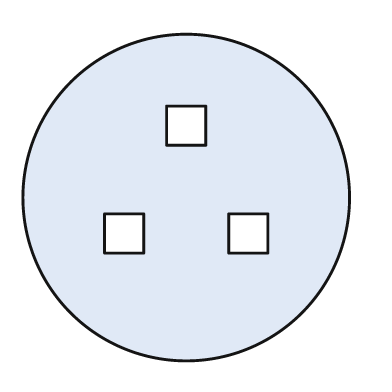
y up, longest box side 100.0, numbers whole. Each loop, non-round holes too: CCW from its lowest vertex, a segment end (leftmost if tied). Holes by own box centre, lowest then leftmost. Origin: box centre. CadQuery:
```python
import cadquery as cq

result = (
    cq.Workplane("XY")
    .moveTo(0.0, 0.0)
    .circle(50.0)
    .moveTo(-25.0, -17.0)
    .lineTo(-13.0, -17.0)
    .lineTo(-13.0, -5.0)
    .lineTo(-25.0, -5.0)
    .close()
    .moveTo(13.0, -17.0)
    .lineTo(25.0, -17.0)
    .lineTo(25.0, -5.0)
    .lineTo(13.0, -5.0)
    .close()
    .moveTo(-6.0, 16.0)
    .lineTo(6.0, 16.0)
    .lineTo(6.0, 28.0)
    .lineTo(-6.0, 28.0)
    .close()
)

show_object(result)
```